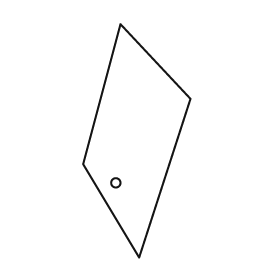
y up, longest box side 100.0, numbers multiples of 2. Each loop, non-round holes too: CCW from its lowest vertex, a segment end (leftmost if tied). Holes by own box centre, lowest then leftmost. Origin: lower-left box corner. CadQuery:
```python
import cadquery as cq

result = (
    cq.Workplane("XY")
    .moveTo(24.0, 0.0)
    .lineTo(46.0, 68.0)
    .lineTo(16.0, 100.0)
    .lineTo(0.0, 40.0)
    .close()
    .moveTo(14.0, 32.0)
    .circle(2.0)
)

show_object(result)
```